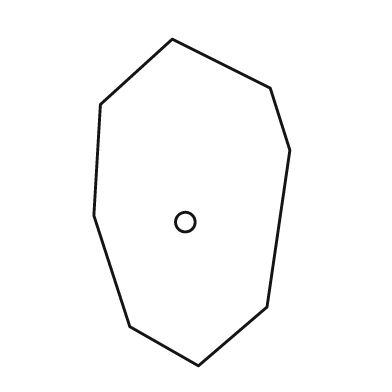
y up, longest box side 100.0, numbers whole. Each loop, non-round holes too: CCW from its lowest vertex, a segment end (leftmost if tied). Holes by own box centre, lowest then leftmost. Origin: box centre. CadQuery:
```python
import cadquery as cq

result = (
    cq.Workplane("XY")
    .moveTo(2.0, -50.0)
    .lineTo(23.0, -32.0)
    .lineTo(30.0, 16.0)
    .lineTo(24.0, 35.0)
    .lineTo(-6.0, 50.0)
    .lineTo(-28.0, 30.0)
    .lineTo(-30.0, -4.0)
    .lineTo(-19.0, -38.0)
    .close()
    .moveTo(-2.0, -6.0)
    .circle(3.0)
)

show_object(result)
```